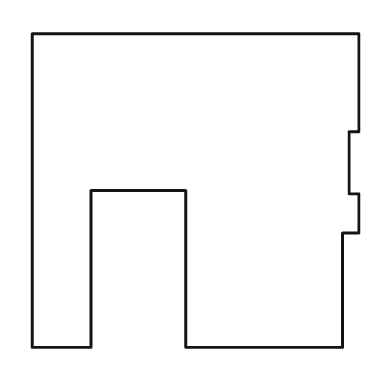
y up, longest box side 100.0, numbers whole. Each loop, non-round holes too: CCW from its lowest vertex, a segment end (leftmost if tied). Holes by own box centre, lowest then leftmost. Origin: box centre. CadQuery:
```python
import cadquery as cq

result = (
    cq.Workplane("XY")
    .moveTo(-50.0, -48.0)
    .lineTo(-32.0, -48.0)
    .lineTo(-32.0, 0.0)
    .lineTo(-3.0, 0.0)
    .lineTo(-3.0, -48.0)
    .lineTo(45.0, -48.0)
    .lineTo(45.0, -13.0)
    .lineTo(50.0, -13.0)
    .lineTo(50.0, -1.0)
    .lineTo(47.0, -1.0)
    .lineTo(47.0, 18.0)
    .lineTo(50.0, 18.0)
    .lineTo(50.0, 48.0)
    .lineTo(-50.0, 48.0)
    .close()
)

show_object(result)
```